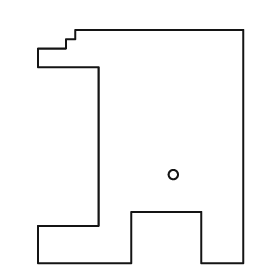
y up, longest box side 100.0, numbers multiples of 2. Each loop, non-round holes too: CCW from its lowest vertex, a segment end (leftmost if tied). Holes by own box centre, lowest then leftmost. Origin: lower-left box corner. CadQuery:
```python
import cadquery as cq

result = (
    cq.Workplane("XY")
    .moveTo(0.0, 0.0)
    .lineTo(40.0, 0.0)
    .lineTo(40.0, 22.0)
    .lineTo(70.0, 22.0)
    .lineTo(70.0, 0.0)
    .lineTo(88.0, 0.0)
    .lineTo(88.0, 100.0)
    .lineTo(16.0, 100.0)
    .lineTo(16.0, 96.0)
    .lineTo(12.0, 96.0)
    .lineTo(12.0, 92.0)
    .lineTo(0.0, 92.0)
    .lineTo(0.0, 84.0)
    .lineTo(26.0, 84.0)
    .lineTo(26.0, 16.0)
    .lineTo(0.0, 16.0)
    .close()
    .moveTo(58.0, 38.0)
    .circle(2.0)
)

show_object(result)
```